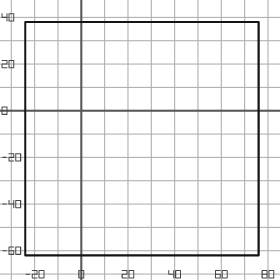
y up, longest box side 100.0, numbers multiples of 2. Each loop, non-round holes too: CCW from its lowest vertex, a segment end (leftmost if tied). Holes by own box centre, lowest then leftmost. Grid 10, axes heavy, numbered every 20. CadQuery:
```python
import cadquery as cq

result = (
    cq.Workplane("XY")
    .moveTo(-24.0, -62.0)
    .lineTo(76.0, -62.0)
    .lineTo(76.0, 38.0)
    .lineTo(-24.0, 38.0)
    .close()
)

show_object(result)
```